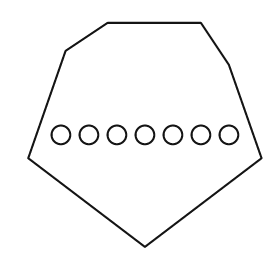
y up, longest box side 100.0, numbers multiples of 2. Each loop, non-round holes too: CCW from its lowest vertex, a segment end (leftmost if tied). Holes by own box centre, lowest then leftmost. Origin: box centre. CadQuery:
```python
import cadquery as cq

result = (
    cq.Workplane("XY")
    .moveTo(0.0, -48.0)
    .lineTo(50.0, -10.0)
    .lineTo(36.0, 30.0)
    .lineTo(24.0, 48.0)
    .lineTo(-16.0, 48.0)
    .lineTo(-34.0, 36.0)
    .lineTo(-50.0, -10.0)
    .close()
    .moveTo(-36.0, 0.0)
    .circle(4.0)
    .moveTo(-24.0, 0.0)
    .circle(4.0)
    .moveTo(-12.0, 0.0)
    .circle(4.0)
    .moveTo(0.0, 0.0)
    .circle(4.0)
    .moveTo(12.0, 0.0)
    .circle(4.0)
    .moveTo(24.0, 0.0)
    .circle(4.0)
    .moveTo(36.0, 0.0)
    .circle(4.0)
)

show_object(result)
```